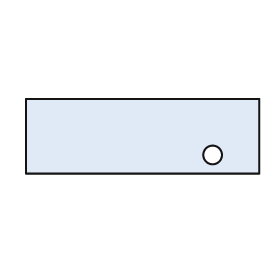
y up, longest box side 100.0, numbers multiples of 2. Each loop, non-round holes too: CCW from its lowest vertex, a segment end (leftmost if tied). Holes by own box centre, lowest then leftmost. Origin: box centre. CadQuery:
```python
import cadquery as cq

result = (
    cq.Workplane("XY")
    .moveTo(-50.0, -16.0)
    .lineTo(50.0, -16.0)
    .lineTo(50.0, 16.0)
    .lineTo(-50.0, 16.0)
    .close()
    .moveTo(30.0, -8.0)
    .circle(4.0)
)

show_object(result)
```